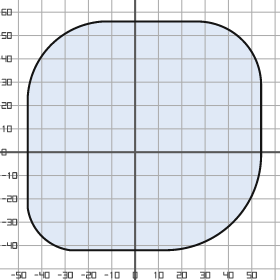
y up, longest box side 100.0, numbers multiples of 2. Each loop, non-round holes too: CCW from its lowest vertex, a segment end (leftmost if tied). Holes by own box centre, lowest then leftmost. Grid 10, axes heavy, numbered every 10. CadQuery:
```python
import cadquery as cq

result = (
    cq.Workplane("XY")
    .moveTo(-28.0, -42.0)
    .lineTo(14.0, -42.0)
    .threePointArc((42.0, -30.0), (54.0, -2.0))
    .lineTo(54.0, 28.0)
    .threePointArc((46.0, 48.0), (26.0, 56.0))
    .lineTo(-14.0, 56.0)
    .threePointArc((-36.0, 46.0), (-46.0, 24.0))
    .lineTo(-46.0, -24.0)
    .threePointArc((-40.0, -36.0), (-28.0, -42.0))
    .close()
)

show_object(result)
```